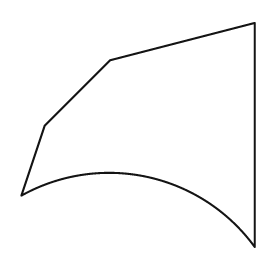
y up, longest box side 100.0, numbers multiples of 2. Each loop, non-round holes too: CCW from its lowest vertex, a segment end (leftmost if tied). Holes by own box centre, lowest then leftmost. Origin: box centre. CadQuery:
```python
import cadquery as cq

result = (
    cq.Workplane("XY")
    .moveTo(50.0, -48.0)
    .lineTo(50.0, 48.0)
    .lineTo(-12.0, 32.0)
    .lineTo(-40.0, 4.0)
    .lineTo(-50.0, -26.0)
    .threePointArc((4.0, -18.0), (50.0, -48.0))
    .close()
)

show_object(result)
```